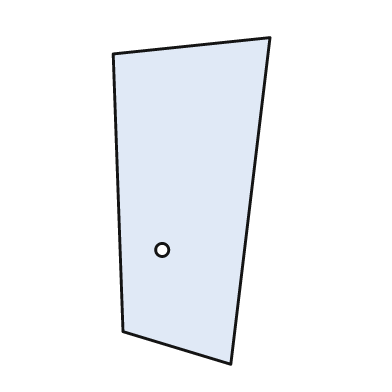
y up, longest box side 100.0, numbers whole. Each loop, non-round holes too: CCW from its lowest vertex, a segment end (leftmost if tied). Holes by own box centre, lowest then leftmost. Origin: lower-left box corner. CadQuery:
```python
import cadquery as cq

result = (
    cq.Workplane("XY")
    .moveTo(36.0, 0.0)
    .lineTo(48.0, 100.0)
    .lineTo(0.0, 95.0)
    .lineTo(3.0, 10.0)
    .close()
    .moveTo(15.0, 35.0)
    .circle(2.0)
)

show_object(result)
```